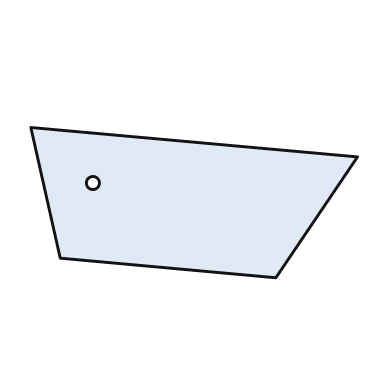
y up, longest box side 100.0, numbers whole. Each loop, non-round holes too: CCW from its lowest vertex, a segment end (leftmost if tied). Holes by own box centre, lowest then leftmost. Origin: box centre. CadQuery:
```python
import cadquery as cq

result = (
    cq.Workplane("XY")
    .moveTo(25.0, -23.0)
    .lineTo(50.0, 14.0)
    .lineTo(-50.0, 23.0)
    .lineTo(-41.0, -17.0)
    .close()
    .moveTo(-31.0, 6.0)
    .circle(2.0)
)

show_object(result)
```